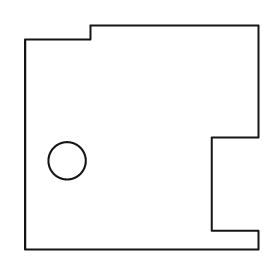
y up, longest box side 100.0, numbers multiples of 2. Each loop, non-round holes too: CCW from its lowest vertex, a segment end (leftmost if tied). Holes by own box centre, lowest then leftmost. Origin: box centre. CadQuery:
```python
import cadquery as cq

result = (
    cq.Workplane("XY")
    .moveTo(-50.0, -48.0)
    .lineTo(50.0, -48.0)
    .lineTo(50.0, -40.0)
    .lineTo(30.0, -40.0)
    .lineTo(30.0, 0.0)
    .lineTo(50.0, 0.0)
    .lineTo(50.0, 48.0)
    .lineTo(-22.0, 48.0)
    .lineTo(-22.0, 42.0)
    .lineTo(-50.0, 42.0)
    .close()
    .moveTo(-32.0, -10.0)
    .circle(8.0)
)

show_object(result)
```